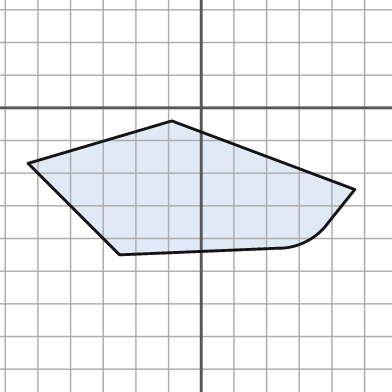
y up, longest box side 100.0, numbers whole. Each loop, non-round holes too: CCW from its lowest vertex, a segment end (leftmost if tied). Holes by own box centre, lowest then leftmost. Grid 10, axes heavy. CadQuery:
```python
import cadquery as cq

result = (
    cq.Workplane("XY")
    .moveTo(-25.0, -45.0)
    .lineTo(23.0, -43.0)
    .threePointArc((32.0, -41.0), (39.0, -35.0))
    .lineTo(47.0, -25.0)
    .lineTo(-9.0, -4.0)
    .lineTo(-53.0, -17.0)
    .close()
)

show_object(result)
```